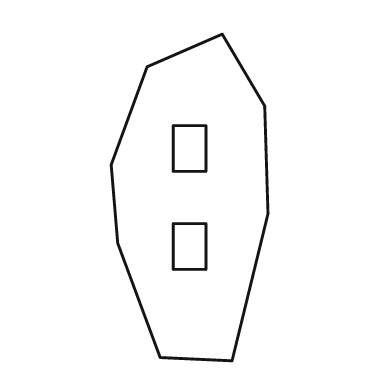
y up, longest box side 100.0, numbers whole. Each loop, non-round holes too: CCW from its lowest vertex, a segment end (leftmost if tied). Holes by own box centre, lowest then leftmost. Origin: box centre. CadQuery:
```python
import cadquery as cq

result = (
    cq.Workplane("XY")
    .moveTo(13.0, -50.0)
    .lineTo(24.0, -5.0)
    .lineTo(23.0, 28.0)
    .lineTo(10.0, 50.0)
    .lineTo(-13.0, 40.0)
    .lineTo(-24.0, 10.0)
    .lineTo(-22.0, -14.0)
    .lineTo(-9.0, -49.0)
    .close()
    .moveTo(-5.0, -22.0)
    .lineTo(5.0, -22.0)
    .lineTo(5.0, -8.0)
    .lineTo(-5.0, -8.0)
    .close()
    .moveTo(-5.0, 8.0)
    .lineTo(5.0, 8.0)
    .lineTo(5.0, 22.0)
    .lineTo(-5.0, 22.0)
    .close()
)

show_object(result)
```